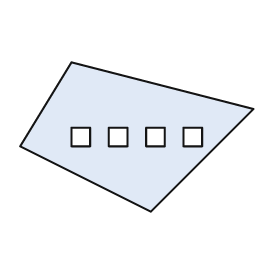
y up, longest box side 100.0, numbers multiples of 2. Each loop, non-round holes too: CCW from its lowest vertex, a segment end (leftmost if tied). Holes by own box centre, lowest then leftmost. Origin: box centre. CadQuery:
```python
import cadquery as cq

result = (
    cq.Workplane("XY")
    .moveTo(6.0, -32.0)
    .lineTo(50.0, 12.0)
    .lineTo(-28.0, 32.0)
    .lineTo(-50.0, -4.0)
    .close()
    .moveTo(-28.0, -4.0)
    .lineTo(-20.0, -4.0)
    .lineTo(-20.0, 4.0)
    .lineTo(-28.0, 4.0)
    .close()
    .moveTo(-12.0, -4.0)
    .lineTo(-4.0, -4.0)
    .lineTo(-4.0, 4.0)
    .lineTo(-12.0, 4.0)
    .close()
    .moveTo(4.0, -4.0)
    .lineTo(12.0, -4.0)
    .lineTo(12.0, 4.0)
    .lineTo(4.0, 4.0)
    .close()
    .moveTo(20.0, -4.0)
    .lineTo(28.0, -4.0)
    .lineTo(28.0, 4.0)
    .lineTo(20.0, 4.0)
    .close()
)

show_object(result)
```